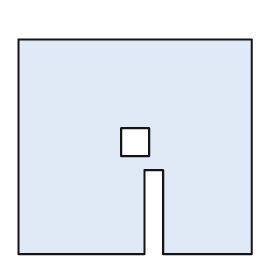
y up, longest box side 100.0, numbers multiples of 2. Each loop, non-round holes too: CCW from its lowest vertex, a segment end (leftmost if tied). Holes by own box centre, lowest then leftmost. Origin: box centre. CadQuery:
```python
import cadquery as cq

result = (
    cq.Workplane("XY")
    .moveTo(-50.0, -46.0)
    .lineTo(4.0, -46.0)
    .lineTo(4.0, -10.0)
    .lineTo(12.0, -10.0)
    .lineTo(12.0, -46.0)
    .lineTo(50.0, -46.0)
    .lineTo(50.0, 46.0)
    .lineTo(-50.0, 46.0)
    .close()
    .moveTo(-6.0, -4.0)
    .lineTo(6.0, -4.0)
    .lineTo(6.0, 8.0)
    .lineTo(-6.0, 8.0)
    .close()
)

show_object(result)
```